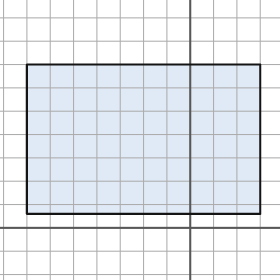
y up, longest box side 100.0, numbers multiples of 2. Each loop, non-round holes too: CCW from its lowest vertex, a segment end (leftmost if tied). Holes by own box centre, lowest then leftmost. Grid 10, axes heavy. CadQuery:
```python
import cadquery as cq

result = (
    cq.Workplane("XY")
    .moveTo(-70.0, 6.0)
    .lineTo(30.0, 6.0)
    .lineTo(30.0, 70.0)
    .lineTo(-70.0, 70.0)
    .close()
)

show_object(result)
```